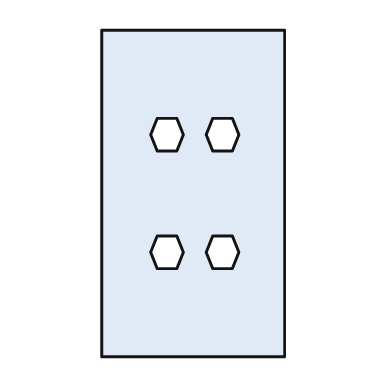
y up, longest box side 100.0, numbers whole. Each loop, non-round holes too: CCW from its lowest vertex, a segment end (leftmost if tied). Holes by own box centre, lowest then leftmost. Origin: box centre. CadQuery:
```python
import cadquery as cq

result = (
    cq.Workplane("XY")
    .moveTo(-28.0, -50.0)
    .lineTo(28.0, -50.0)
    .lineTo(28.0, 50.0)
    .lineTo(-28.0, 50.0)
    .close()
    .moveTo(-11.0, -23.0)
    .lineTo(-5.0, -23.0)
    .lineTo(-3.0, -18.0)
    .lineTo(-5.0, -13.0)
    .lineTo(-11.0, -13.0)
    .lineTo(-13.0, -18.0)
    .close()
    .moveTo(6.0, -23.0)
    .lineTo(12.0, -23.0)
    .lineTo(14.0, -18.0)
    .lineTo(12.0, -13.0)
    .lineTo(6.0, -13.0)
    .lineTo(4.0, -18.0)
    .close()
    .moveTo(-11.0, 13.0)
    .lineTo(-5.0, 13.0)
    .lineTo(-3.0, 18.0)
    .lineTo(-5.0, 23.0)
    .lineTo(-11.0, 23.0)
    .lineTo(-13.0, 18.0)
    .close()
    .moveTo(6.0, 13.0)
    .lineTo(12.0, 13.0)
    .lineTo(14.0, 18.0)
    .lineTo(12.0, 23.0)
    .lineTo(6.0, 23.0)
    .lineTo(4.0, 18.0)
    .close()
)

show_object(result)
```